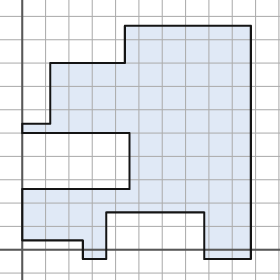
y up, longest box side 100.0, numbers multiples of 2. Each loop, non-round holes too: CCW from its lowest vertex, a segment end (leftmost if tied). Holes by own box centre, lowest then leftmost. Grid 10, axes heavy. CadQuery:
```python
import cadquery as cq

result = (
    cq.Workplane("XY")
    .moveTo(26.0, -4.0)
    .lineTo(36.0, -4.0)
    .lineTo(36.0, 16.0)
    .lineTo(78.0, 16.0)
    .lineTo(78.0, -4.0)
    .lineTo(98.0, -4.0)
    .lineTo(98.0, 96.0)
    .lineTo(44.0, 96.0)
    .lineTo(44.0, 80.0)
    .lineTo(12.0, 80.0)
    .lineTo(12.0, 54.0)
    .lineTo(0.0, 54.0)
    .lineTo(0.0, 50.0)
    .lineTo(46.0, 50.0)
    .lineTo(46.0, 26.0)
    .lineTo(0.0, 26.0)
    .lineTo(0.0, 4.0)
    .lineTo(26.0, 4.0)
    .close()
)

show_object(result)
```